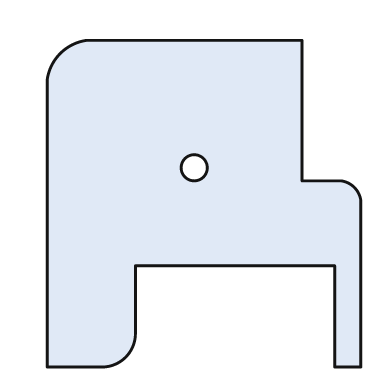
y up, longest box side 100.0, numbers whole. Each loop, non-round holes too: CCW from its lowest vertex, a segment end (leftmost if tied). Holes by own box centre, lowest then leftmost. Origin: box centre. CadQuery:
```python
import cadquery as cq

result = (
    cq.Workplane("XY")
    .moveTo(-48.0, -50.0)
    .lineTo(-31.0, -50.0)
    .threePointArc((-24.0, -47.0), (-21.0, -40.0))
    .lineTo(-21.0, -19.0)
    .lineTo(40.0, -19.0)
    .lineTo(40.0, -50.0)
    .lineTo(48.0, -50.0)
    .lineTo(48.0, 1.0)
    .threePointArc((46.0, 5.0), (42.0, 7.0))
    .lineTo(30.0, 7.0)
    .lineTo(30.0, 50.0)
    .lineTo(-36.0, 50.0)
    .threePointArc((-44.0, 46.0), (-48.0, 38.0))
    .close()
    .moveTo(-3.0, 11.0)
    .circle(4.0)
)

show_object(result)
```